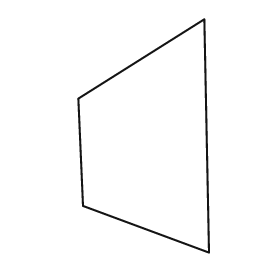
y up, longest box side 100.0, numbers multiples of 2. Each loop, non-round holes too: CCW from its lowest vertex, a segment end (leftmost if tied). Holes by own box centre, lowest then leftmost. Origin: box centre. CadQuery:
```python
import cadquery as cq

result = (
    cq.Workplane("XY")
    .moveTo(28.0, -50.0)
    .lineTo(26.0, 50.0)
    .lineTo(-28.0, 16.0)
    .lineTo(-26.0, -30.0)
    .close()
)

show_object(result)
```